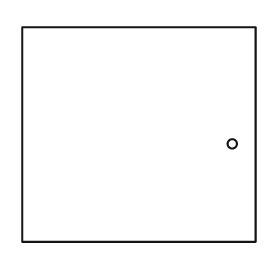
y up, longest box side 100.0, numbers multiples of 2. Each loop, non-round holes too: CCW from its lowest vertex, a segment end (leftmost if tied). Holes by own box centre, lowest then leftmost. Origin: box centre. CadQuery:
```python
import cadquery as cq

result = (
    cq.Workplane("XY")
    .moveTo(-50.0, -46.0)
    .lineTo(50.0, -46.0)
    .lineTo(50.0, 46.0)
    .lineTo(-50.0, 46.0)
    .close()
    .moveTo(40.0, -4.0)
    .circle(2.0)
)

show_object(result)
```